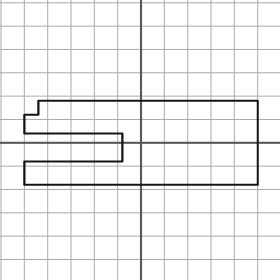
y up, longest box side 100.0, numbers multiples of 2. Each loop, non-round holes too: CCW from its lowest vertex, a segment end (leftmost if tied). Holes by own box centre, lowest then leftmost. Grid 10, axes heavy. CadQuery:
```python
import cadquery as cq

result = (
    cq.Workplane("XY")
    .moveTo(-50.0, -18.0)
    .lineTo(50.0, -18.0)
    .lineTo(50.0, 18.0)
    .lineTo(-44.0, 18.0)
    .lineTo(-44.0, 12.0)
    .lineTo(-50.0, 12.0)
    .lineTo(-50.0, 4.0)
    .lineTo(-8.0, 4.0)
    .lineTo(-8.0, -8.0)
    .lineTo(-50.0, -8.0)
    .close()
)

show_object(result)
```